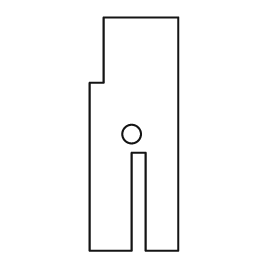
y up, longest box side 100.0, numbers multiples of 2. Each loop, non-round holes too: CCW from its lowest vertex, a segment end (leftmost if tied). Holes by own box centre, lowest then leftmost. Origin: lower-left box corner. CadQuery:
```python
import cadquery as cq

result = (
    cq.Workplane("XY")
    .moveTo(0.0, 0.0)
    .lineTo(18.0, 0.0)
    .lineTo(18.0, 42.0)
    .lineTo(24.0, 42.0)
    .lineTo(24.0, 0.0)
    .lineTo(38.0, 0.0)
    .lineTo(38.0, 100.0)
    .lineTo(6.0, 100.0)
    .lineTo(6.0, 72.0)
    .lineTo(0.0, 72.0)
    .close()
    .moveTo(18.0, 50.0)
    .circle(4.0)
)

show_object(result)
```